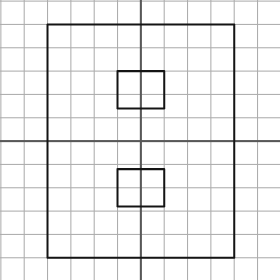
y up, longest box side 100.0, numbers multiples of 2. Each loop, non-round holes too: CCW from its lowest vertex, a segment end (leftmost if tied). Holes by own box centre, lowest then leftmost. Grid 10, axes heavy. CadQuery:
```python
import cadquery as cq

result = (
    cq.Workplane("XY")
    .moveTo(-40.0, -50.0)
    .lineTo(40.0, -50.0)
    .lineTo(40.0, 50.0)
    .lineTo(-40.0, 50.0)
    .close()
    .moveTo(-10.0, -28.0)
    .lineTo(10.0, -28.0)
    .lineTo(10.0, -12.0)
    .lineTo(-10.0, -12.0)
    .close()
    .moveTo(-10.0, 14.0)
    .lineTo(10.0, 14.0)
    .lineTo(10.0, 30.0)
    .lineTo(-10.0, 30.0)
    .close()
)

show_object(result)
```